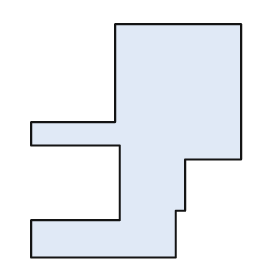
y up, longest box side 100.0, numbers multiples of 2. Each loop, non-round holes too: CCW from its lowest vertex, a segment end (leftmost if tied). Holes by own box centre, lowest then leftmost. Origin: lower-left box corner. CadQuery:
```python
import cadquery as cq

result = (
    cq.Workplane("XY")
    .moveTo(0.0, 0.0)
    .lineTo(62.0, 0.0)
    .lineTo(62.0, 20.0)
    .lineTo(66.0, 20.0)
    .lineTo(66.0, 42.0)
    .lineTo(90.0, 42.0)
    .lineTo(90.0, 100.0)
    .lineTo(36.0, 100.0)
    .lineTo(36.0, 58.0)
    .lineTo(0.0, 58.0)
    .lineTo(0.0, 48.0)
    .lineTo(38.0, 48.0)
    .lineTo(38.0, 16.0)
    .lineTo(0.0, 16.0)
    .close()
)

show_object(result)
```